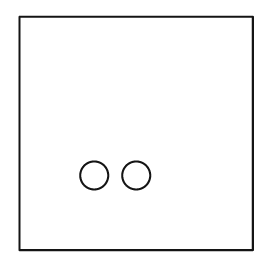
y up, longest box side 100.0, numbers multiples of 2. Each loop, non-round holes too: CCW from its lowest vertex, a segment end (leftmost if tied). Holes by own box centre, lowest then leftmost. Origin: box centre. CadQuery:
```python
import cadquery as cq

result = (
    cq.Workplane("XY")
    .moveTo(-50.0, -50.0)
    .lineTo(50.0, -50.0)
    .lineTo(50.0, 50.0)
    .lineTo(-50.0, 50.0)
    .close()
    .moveTo(-18.0, -18.0)
    .circle(6.0)
    .moveTo(0.0, -18.0)
    .circle(6.0)
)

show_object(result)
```